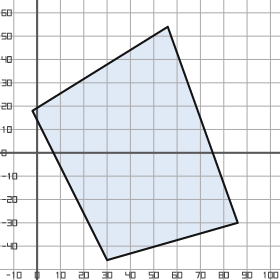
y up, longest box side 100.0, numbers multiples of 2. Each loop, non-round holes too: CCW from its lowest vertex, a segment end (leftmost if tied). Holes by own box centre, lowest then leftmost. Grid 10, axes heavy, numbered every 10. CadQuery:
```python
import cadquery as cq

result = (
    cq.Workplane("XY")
    .moveTo(30.0, -46.0)
    .lineTo(86.0, -30.0)
    .lineTo(56.0, 54.0)
    .lineTo(-2.0, 18.0)
    .close()
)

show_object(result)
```